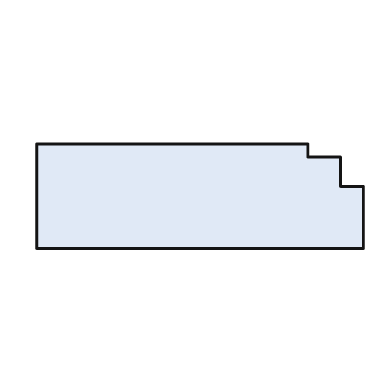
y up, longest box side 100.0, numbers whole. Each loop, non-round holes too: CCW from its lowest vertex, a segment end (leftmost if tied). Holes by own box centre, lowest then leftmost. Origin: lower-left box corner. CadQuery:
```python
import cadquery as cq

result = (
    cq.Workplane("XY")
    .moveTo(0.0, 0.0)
    .lineTo(100.0, 0.0)
    .lineTo(100.0, 19.0)
    .lineTo(93.0, 19.0)
    .lineTo(93.0, 28.0)
    .lineTo(83.0, 28.0)
    .lineTo(83.0, 32.0)
    .lineTo(0.0, 32.0)
    .close()
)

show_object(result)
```